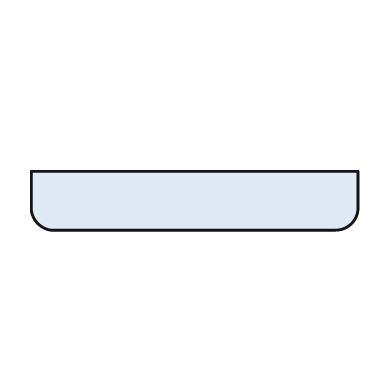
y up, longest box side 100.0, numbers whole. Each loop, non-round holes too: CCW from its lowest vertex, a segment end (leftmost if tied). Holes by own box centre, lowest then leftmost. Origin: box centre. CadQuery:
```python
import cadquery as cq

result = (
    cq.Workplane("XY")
    .moveTo(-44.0, -9.0)
    .lineTo(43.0, -9.0)
    .threePointArc((48.0, -7.0), (50.0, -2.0))
    .lineTo(50.0, 9.0)
    .lineTo(-50.0, 9.0)
    .lineTo(-50.0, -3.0)
    .threePointArc((-48.0, -7.0), (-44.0, -9.0))
    .close()
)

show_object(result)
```